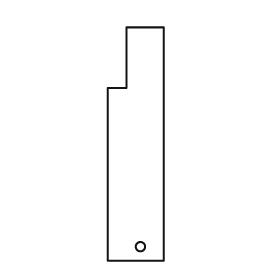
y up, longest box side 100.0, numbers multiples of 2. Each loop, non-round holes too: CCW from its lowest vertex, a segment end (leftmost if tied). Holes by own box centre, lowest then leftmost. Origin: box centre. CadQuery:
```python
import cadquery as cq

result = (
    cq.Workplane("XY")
    .moveTo(-12.0, -50.0)
    .lineTo(12.0, -50.0)
    .lineTo(12.0, 50.0)
    .lineTo(-4.0, 50.0)
    .lineTo(-4.0, 24.0)
    .lineTo(-12.0, 24.0)
    .close()
    .moveTo(2.0, -44.0)
    .circle(2.0)
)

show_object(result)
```